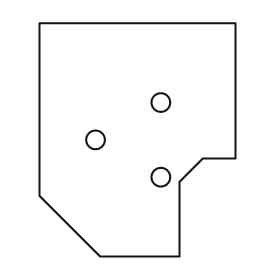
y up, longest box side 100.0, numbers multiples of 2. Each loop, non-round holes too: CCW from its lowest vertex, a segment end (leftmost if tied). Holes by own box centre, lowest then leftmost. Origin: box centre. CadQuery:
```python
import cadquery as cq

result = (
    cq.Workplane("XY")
    .moveTo(-16.0, -50.0)
    .lineTo(18.0, -50.0)
    .lineTo(18.0, -18.0)
    .lineTo(28.0, -8.0)
    .lineTo(42.0, -8.0)
    .lineTo(42.0, 50.0)
    .lineTo(-42.0, 50.0)
    .lineTo(-42.0, -24.0)
    .close()
    .moveTo(10.0, -16.0)
    .circle(4.0)
    .moveTo(-18.0, 0.0)
    .circle(4.0)
    .moveTo(10.0, 16.0)
    .circle(4.0)
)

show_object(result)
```